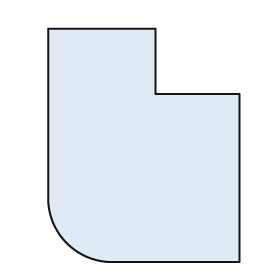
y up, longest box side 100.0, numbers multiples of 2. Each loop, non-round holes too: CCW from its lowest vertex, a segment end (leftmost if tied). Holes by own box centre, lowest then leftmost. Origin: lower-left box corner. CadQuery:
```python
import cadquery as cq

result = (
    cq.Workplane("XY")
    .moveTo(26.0, 0.0)
    .lineTo(82.0, 0.0)
    .lineTo(82.0, 72.0)
    .lineTo(46.0, 72.0)
    .lineTo(46.0, 100.0)
    .lineTo(0.0, 100.0)
    .lineTo(0.0, 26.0)
    .threePointArc((8.0, 8.0), (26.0, 0.0))
    .close()
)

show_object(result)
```